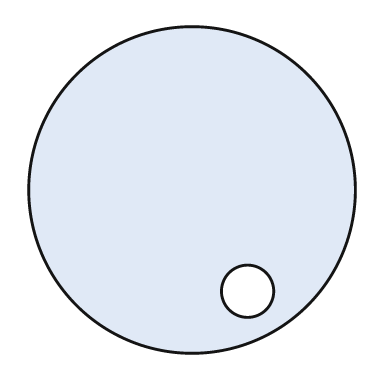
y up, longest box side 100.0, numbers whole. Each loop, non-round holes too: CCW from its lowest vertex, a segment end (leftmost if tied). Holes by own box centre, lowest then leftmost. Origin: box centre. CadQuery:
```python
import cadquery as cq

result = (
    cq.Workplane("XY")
    .moveTo(0.0, 0.0)
    .circle(50.0)
    .moveTo(17.0, -31.0)
    .circle(8.0)
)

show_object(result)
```